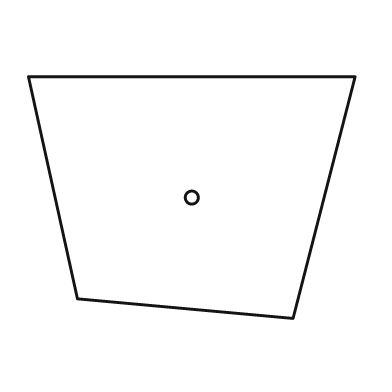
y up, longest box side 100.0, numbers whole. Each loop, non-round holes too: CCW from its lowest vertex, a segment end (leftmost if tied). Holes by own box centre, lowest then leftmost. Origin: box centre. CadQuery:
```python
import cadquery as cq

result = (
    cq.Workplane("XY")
    .moveTo(31.0, -37.0)
    .lineTo(50.0, 37.0)
    .lineTo(-50.0, 37.0)
    .lineTo(-35.0, -31.0)
    .close()
    .moveTo(0.0, 0.0)
    .circle(2.0)
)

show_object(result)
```